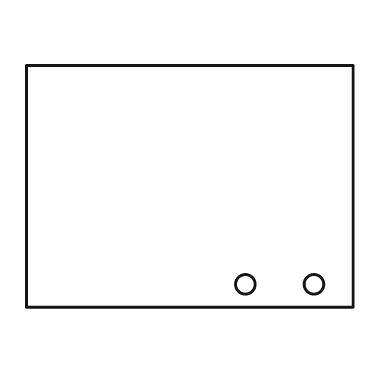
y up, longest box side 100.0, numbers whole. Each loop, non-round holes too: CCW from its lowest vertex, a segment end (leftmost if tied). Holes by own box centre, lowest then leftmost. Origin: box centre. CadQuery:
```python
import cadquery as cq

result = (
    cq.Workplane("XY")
    .moveTo(-50.0, -37.0)
    .lineTo(50.0, -37.0)
    .lineTo(50.0, 37.0)
    .lineTo(-50.0, 37.0)
    .close()
    .moveTo(17.0, -30.0)
    .circle(3.0)
    .moveTo(38.0, -30.0)
    .circle(3.0)
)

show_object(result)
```